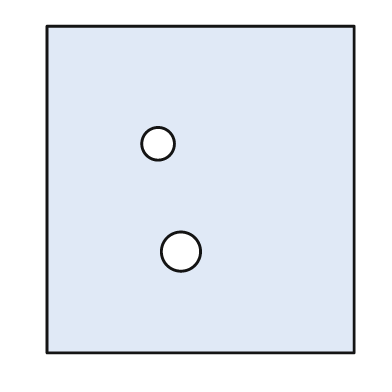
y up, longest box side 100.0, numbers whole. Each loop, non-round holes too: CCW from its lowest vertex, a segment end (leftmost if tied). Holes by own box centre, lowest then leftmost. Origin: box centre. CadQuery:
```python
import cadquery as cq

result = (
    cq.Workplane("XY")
    .moveTo(-47.0, -50.0)
    .lineTo(47.0, -50.0)
    .lineTo(47.0, 50.0)
    .lineTo(-47.0, 50.0)
    .close()
    .moveTo(-6.0, -19.0)
    .circle(6.0)
    .moveTo(-13.0, 14.0)
    .circle(5.0)
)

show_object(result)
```